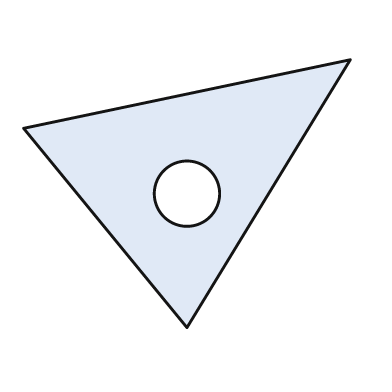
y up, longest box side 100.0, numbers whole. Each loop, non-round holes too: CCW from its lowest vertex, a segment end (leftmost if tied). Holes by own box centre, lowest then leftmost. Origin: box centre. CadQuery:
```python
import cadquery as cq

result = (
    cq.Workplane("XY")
    .moveTo(0.0, -41.0)
    .lineTo(50.0, 41.0)
    .lineTo(-50.0, 20.0)
    .close()
    .moveTo(0.0, 0.0)
    .circle(10.0)
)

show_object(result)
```